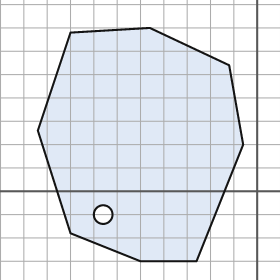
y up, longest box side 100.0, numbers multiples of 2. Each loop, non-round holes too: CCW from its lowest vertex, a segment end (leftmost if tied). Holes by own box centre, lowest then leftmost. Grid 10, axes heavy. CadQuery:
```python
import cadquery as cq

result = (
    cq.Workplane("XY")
    .moveTo(-50.0, -30.0)
    .lineTo(-26.0, -30.0)
    .lineTo(-6.0, 20.0)
    .lineTo(-12.0, 54.0)
    .lineTo(-46.0, 70.0)
    .lineTo(-80.0, 68.0)
    .lineTo(-94.0, 26.0)
    .lineTo(-80.0, -18.0)
    .close()
    .moveTo(-66.0, -10.0)
    .circle(4.0)
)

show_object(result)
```